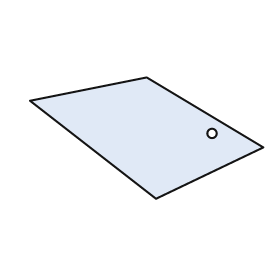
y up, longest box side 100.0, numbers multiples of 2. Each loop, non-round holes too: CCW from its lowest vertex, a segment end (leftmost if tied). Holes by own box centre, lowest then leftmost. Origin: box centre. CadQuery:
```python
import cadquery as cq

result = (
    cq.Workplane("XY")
    .moveTo(4.0, -26.0)
    .lineTo(50.0, -4.0)
    .lineTo(0.0, 26.0)
    .lineTo(-50.0, 16.0)
    .close()
    .moveTo(28.0, 2.0)
    .circle(2.0)
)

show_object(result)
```